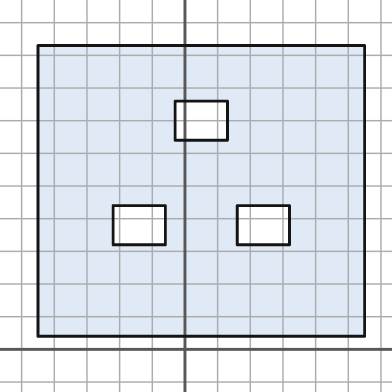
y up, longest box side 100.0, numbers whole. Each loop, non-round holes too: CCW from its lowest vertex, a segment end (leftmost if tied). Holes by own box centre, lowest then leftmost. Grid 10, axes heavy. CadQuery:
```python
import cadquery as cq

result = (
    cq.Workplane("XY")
    .moveTo(-45.0, 4.0)
    .lineTo(55.0, 4.0)
    .lineTo(55.0, 93.0)
    .lineTo(-45.0, 93.0)
    .close()
    .moveTo(-22.0, 32.0)
    .lineTo(-6.0, 32.0)
    .lineTo(-6.0, 44.0)
    .lineTo(-22.0, 44.0)
    .close()
    .moveTo(16.0, 32.0)
    .lineTo(32.0, 32.0)
    .lineTo(32.0, 44.0)
    .lineTo(16.0, 44.0)
    .close()
    .moveTo(-3.0, 64.0)
    .lineTo(13.0, 64.0)
    .lineTo(13.0, 76.0)
    .lineTo(-3.0, 76.0)
    .close()
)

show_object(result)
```